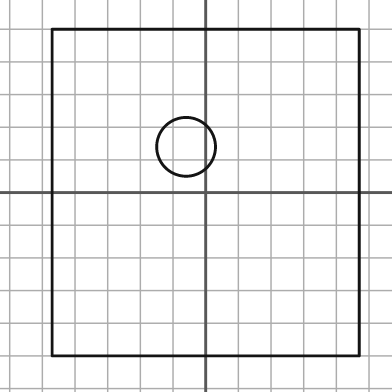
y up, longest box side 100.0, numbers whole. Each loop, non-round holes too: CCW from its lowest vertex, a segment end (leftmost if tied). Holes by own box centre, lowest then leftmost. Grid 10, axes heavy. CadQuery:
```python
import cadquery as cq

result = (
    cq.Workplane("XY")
    .moveTo(-47.0, -50.0)
    .lineTo(47.0, -50.0)
    .lineTo(47.0, 50.0)
    .lineTo(-47.0, 50.0)
    .close()
    .moveTo(-6.0, 14.0)
    .circle(9.0)
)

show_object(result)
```